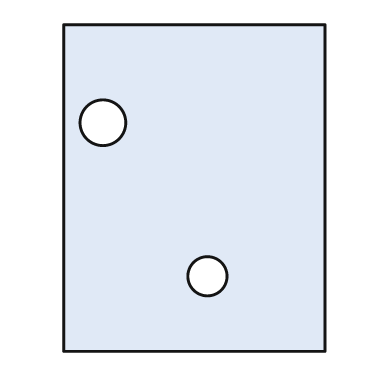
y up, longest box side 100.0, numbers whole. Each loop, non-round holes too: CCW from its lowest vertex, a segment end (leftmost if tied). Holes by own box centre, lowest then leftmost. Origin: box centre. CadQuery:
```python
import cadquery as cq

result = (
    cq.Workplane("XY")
    .moveTo(-40.0, -50.0)
    .lineTo(40.0, -50.0)
    .lineTo(40.0, 50.0)
    .lineTo(-40.0, 50.0)
    .close()
    .moveTo(4.0, -27.0)
    .circle(6.0)
    .moveTo(-28.0, 20.0)
    .circle(7.0)
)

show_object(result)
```